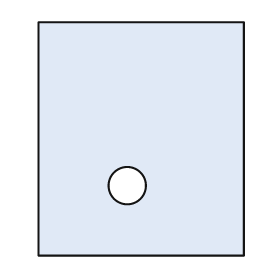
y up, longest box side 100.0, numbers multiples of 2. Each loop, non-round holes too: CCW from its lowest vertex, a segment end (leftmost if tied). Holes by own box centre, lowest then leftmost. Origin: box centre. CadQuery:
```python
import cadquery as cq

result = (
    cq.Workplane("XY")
    .moveTo(-44.0, -50.0)
    .lineTo(44.0, -50.0)
    .lineTo(44.0, 50.0)
    .lineTo(-44.0, 50.0)
    .close()
    .moveTo(-6.0, -20.0)
    .circle(8.0)
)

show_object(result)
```